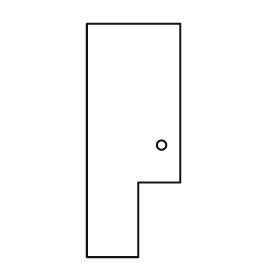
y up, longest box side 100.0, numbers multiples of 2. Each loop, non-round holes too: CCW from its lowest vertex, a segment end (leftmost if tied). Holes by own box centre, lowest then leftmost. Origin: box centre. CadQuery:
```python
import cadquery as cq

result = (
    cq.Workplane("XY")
    .moveTo(-20.0, -50.0)
    .lineTo(2.0, -50.0)
    .lineTo(2.0, -18.0)
    .lineTo(20.0, -18.0)
    .lineTo(20.0, 50.0)
    .lineTo(-20.0, 50.0)
    .close()
    .moveTo(12.0, -2.0)
    .circle(2.0)
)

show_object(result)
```